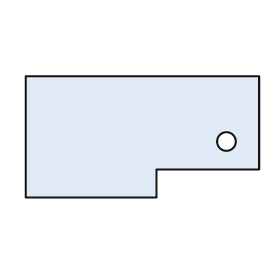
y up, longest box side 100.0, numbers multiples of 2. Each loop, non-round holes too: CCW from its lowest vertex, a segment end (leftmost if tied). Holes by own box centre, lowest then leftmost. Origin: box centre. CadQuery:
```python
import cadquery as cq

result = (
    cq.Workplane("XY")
    .moveTo(-50.0, -26.0)
    .lineTo(6.0, -26.0)
    .lineTo(6.0, -14.0)
    .lineTo(50.0, -14.0)
    .lineTo(50.0, 26.0)
    .lineTo(-50.0, 26.0)
    .close()
    .moveTo(36.0, -2.0)
    .circle(4.0)
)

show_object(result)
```